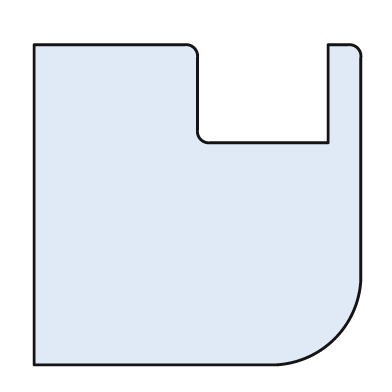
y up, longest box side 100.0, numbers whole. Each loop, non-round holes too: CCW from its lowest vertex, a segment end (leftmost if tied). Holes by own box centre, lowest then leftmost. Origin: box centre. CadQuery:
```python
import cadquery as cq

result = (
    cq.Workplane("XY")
    .moveTo(-50.0, -49.0)
    .lineTo(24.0, -49.0)
    .threePointArc((42.0, -41.0), (50.0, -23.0))
    .lineTo(50.0, 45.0)
    .threePointArc((49.0, 48.0), (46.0, 49.0))
    .lineTo(40.0, 49.0)
    .lineTo(40.0, 19.0)
    .lineTo(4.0, 19.0)
    .threePointArc((1.0, 20.0), (0.0, 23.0))
    .lineTo(0.0, 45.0)
    .threePointArc((-1.0, 48.0), (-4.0, 49.0))
    .lineTo(-50.0, 49.0)
    .close()
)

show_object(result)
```